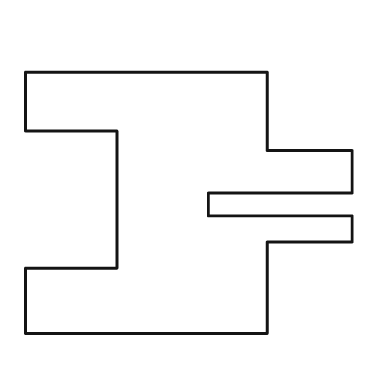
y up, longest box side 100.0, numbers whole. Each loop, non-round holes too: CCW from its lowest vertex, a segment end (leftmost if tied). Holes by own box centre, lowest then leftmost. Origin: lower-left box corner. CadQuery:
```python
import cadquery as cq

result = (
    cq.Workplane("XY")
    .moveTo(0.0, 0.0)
    .lineTo(74.0, 0.0)
    .lineTo(74.0, 28.0)
    .lineTo(100.0, 28.0)
    .lineTo(100.0, 36.0)
    .lineTo(56.0, 36.0)
    .lineTo(56.0, 43.0)
    .lineTo(100.0, 43.0)
    .lineTo(100.0, 56.0)
    .lineTo(74.0, 56.0)
    .lineTo(74.0, 80.0)
    .lineTo(0.0, 80.0)
    .lineTo(0.0, 62.0)
    .lineTo(28.0, 62.0)
    .lineTo(28.0, 20.0)
    .lineTo(0.0, 20.0)
    .close()
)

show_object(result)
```